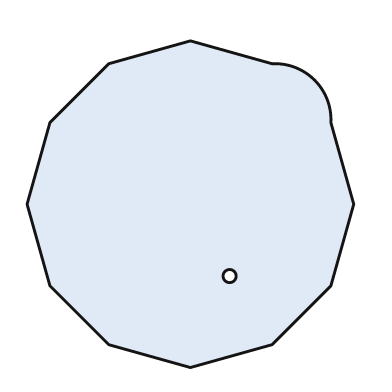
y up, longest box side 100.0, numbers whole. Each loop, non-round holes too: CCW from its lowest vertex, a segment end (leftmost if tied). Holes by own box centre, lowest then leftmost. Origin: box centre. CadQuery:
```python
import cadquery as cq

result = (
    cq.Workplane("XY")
    .moveTo(0.0, -50.0)
    .lineTo(25.0, -43.0)
    .lineTo(43.0, -25.0)
    .lineTo(50.0, 0.0)
    .lineTo(43.0, 25.0)
    .threePointArc((38.0, 38.0), (25.0, 43.0))
    .lineTo(0.0, 50.0)
    .lineTo(-25.0, 43.0)
    .lineTo(-43.0, 25.0)
    .lineTo(-50.0, 0.0)
    .lineTo(-43.0, -25.0)
    .lineTo(-25.0, -43.0)
    .close()
    .moveTo(12.0, -22.0)
    .circle(2.0)
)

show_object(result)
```